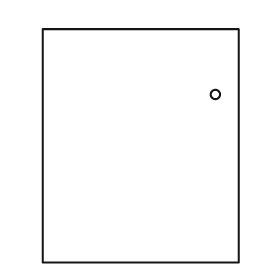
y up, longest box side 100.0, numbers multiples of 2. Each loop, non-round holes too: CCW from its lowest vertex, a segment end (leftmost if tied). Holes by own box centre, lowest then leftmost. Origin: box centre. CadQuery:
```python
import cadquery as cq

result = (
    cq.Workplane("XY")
    .moveTo(-42.0, -50.0)
    .lineTo(42.0, -50.0)
    .lineTo(42.0, 50.0)
    .lineTo(-42.0, 50.0)
    .close()
    .moveTo(32.0, 22.0)
    .circle(2.0)
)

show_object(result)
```